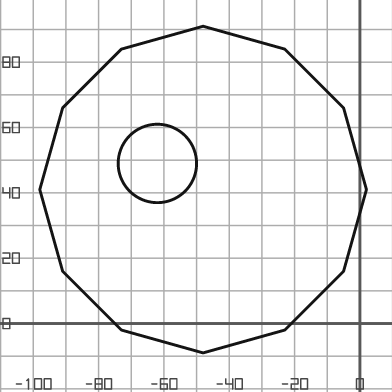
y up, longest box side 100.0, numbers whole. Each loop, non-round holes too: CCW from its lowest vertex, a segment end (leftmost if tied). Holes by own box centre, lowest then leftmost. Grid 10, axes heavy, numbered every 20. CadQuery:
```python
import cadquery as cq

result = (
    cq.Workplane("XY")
    .moveTo(-48.0, -9.0)
    .lineTo(-23.0, -2.0)
    .lineTo(-5.0, 16.0)
    .lineTo(2.0, 41.0)
    .lineTo(-5.0, 66.0)
    .lineTo(-23.0, 84.0)
    .lineTo(-48.0, 91.0)
    .lineTo(-73.0, 84.0)
    .lineTo(-91.0, 66.0)
    .lineTo(-98.0, 41.0)
    .lineTo(-91.0, 16.0)
    .lineTo(-73.0, -2.0)
    .close()
    .moveTo(-62.0, 49.0)
    .circle(12.0)
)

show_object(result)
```